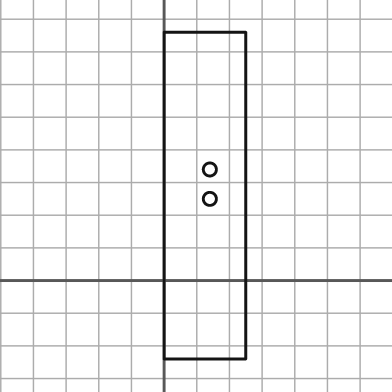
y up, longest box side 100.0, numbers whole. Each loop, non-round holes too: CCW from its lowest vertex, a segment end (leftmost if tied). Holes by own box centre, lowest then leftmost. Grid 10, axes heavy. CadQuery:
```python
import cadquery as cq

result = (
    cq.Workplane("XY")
    .moveTo(0.0, -24.0)
    .lineTo(25.0, -24.0)
    .lineTo(25.0, 76.0)
    .lineTo(0.0, 76.0)
    .close()
    .moveTo(14.0, 25.0)
    .circle(2.0)
    .moveTo(14.0, 34.0)
    .circle(2.0)
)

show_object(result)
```